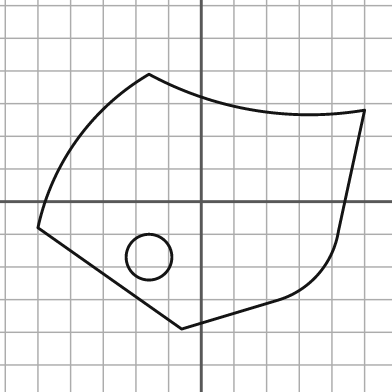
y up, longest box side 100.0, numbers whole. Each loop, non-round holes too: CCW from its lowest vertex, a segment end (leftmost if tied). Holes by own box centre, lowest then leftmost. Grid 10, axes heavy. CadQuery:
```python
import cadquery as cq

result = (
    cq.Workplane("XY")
    .moveTo(-6.0, -39.0)
    .lineTo(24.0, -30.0)
    .threePointArc((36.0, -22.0), (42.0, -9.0))
    .lineTo(50.0, 28.0)
    .threePointArc((16.0, 28.0), (-16.0, 39.0))
    .threePointArc((-38.0, 19.0), (-50.0, -8.0))
    .close()
    .moveTo(-16.0, -17.0)
    .circle(7.0)
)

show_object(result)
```